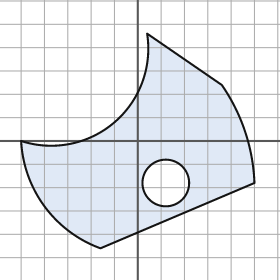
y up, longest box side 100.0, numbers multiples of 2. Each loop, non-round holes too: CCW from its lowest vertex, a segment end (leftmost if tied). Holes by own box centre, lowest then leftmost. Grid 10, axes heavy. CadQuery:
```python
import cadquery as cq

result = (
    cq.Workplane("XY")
    .moveTo(-16.0, -46.0)
    .lineTo(50.0, -18.0)
    .threePointArc((46.0, 4.0), (36.0, 24.0))
    .lineTo(4.0, 46.0)
    .threePointArc((-10.0, 8.0), (-50.0, 0.0))
    .threePointArc((-40.0, -28.0), (-16.0, -46.0))
    .close()
    .moveTo(12.0, -18.0)
    .circle(10.0)
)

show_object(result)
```